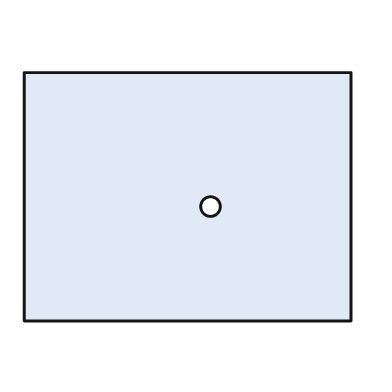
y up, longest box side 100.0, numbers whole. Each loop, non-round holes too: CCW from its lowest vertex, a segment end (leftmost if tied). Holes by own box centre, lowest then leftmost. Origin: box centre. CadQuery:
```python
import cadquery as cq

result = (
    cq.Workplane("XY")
    .moveTo(-50.0, -38.0)
    .lineTo(50.0, -38.0)
    .lineTo(50.0, 38.0)
    .lineTo(-50.0, 38.0)
    .close()
    .moveTo(7.0, -3.0)
    .circle(3.0)
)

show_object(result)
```